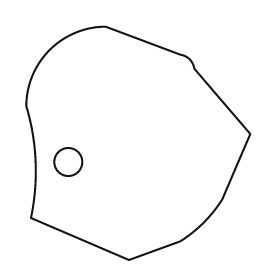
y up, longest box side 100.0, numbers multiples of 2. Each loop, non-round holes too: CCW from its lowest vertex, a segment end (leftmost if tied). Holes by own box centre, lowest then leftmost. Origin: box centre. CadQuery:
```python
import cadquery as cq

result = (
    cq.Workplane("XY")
    .moveTo(-4.0, -50.0)
    .lineTo(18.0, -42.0)
    .threePointArc((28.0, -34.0), (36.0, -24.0))
    .lineTo(48.0, 4.0)
    .lineTo(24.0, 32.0)
    .threePointArc((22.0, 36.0), (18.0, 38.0))
    .lineTo(-14.0, 50.0)
    .threePointArc((-38.0, 40.0), (-48.0, 16.0))
    .threePointArc((-44.0, -8.0), (-46.0, -32.0))
    .close()
    .moveTo(-30.0, -8.0)
    .circle(6.0)
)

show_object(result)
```